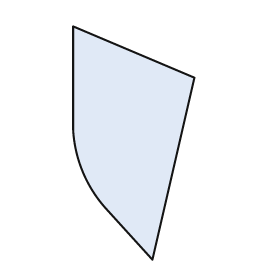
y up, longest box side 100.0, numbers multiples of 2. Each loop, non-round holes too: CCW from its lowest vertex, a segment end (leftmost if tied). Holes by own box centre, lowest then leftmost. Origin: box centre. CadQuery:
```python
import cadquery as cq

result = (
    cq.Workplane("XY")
    .moveTo(8.0, -50.0)
    .lineTo(26.0, 28.0)
    .lineTo(-26.0, 50.0)
    .lineTo(-26.0, 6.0)
    .threePointArc((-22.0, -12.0), (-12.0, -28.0))
    .close()
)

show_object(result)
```